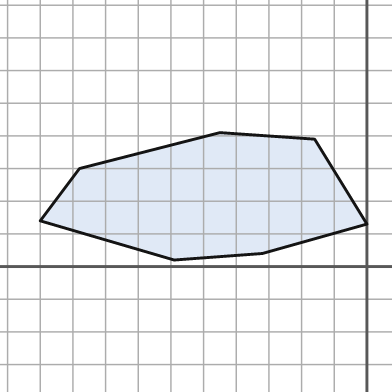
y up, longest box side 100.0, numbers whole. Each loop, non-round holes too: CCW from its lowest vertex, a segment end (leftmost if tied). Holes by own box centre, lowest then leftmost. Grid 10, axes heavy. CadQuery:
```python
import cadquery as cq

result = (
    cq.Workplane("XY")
    .moveTo(-59.0, 2.0)
    .lineTo(-32.0, 4.0)
    .lineTo(0.0, 13.0)
    .lineTo(-16.0, 39.0)
    .lineTo(-45.0, 41.0)
    .lineTo(-88.0, 30.0)
    .lineTo(-100.0, 14.0)
    .close()
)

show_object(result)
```